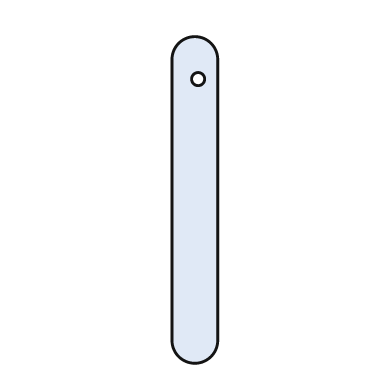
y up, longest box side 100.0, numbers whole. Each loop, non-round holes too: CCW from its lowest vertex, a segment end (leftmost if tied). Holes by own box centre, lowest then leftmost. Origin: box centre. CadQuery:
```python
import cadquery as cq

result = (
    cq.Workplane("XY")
    .moveTo(-7.0, -43.0)
    .threePointArc((0.0, -50.0), (7.0, -43.0))
    .lineTo(7.0, 43.0)
    .threePointArc((0.0, 50.0), (-7.0, 43.0))
    .close()
    .moveTo(1.0, 37.0)
    .circle(2.0)
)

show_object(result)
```